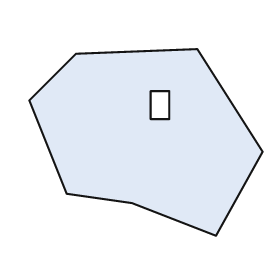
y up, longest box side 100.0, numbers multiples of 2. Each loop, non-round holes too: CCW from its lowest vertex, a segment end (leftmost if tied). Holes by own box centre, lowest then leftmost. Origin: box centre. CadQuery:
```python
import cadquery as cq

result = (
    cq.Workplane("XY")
    .moveTo(30.0, -40.0)
    .lineTo(50.0, -4.0)
    .lineTo(22.0, 40.0)
    .lineTo(-30.0, 38.0)
    .lineTo(-50.0, 18.0)
    .lineTo(-34.0, -22.0)
    .lineTo(-6.0, -26.0)
    .close()
    .moveTo(2.0, 10.0)
    .lineTo(10.0, 10.0)
    .lineTo(10.0, 22.0)
    .lineTo(2.0, 22.0)
    .close()
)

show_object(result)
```